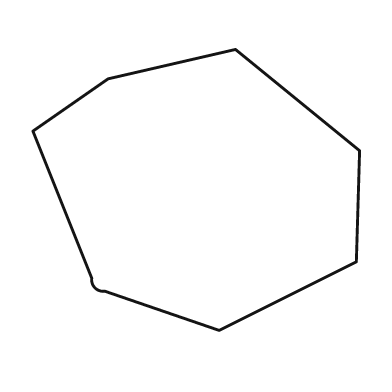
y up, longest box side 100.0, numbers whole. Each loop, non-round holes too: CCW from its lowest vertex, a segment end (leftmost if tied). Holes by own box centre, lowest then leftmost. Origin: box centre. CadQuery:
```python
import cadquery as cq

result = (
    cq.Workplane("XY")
    .moveTo(7.0, -43.0)
    .lineTo(49.0, -22.0)
    .lineTo(50.0, 12.0)
    .lineTo(12.0, 43.0)
    .lineTo(-27.0, 34.0)
    .lineTo(-50.0, 18.0)
    .lineTo(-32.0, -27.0)
    .threePointArc((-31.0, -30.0), (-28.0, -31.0))
    .close()
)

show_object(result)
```